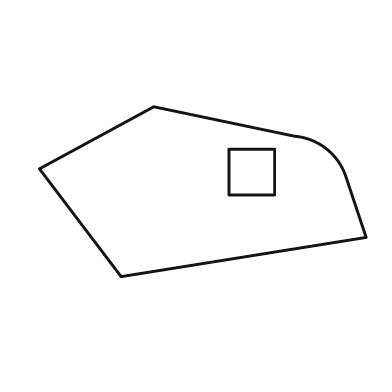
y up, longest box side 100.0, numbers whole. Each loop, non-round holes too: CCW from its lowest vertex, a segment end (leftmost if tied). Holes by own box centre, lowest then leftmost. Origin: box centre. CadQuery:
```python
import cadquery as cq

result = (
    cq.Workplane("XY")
    .moveTo(-25.0, -26.0)
    .lineTo(50.0, -14.0)
    .lineTo(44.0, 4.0)
    .threePointArc((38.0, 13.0), (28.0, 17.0))
    .lineTo(-15.0, 26.0)
    .lineTo(-50.0, 7.0)
    .close()
    .moveTo(8.0, -1.0)
    .lineTo(22.0, -1.0)
    .lineTo(22.0, 13.0)
    .lineTo(8.0, 13.0)
    .close()
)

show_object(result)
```